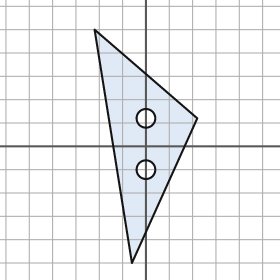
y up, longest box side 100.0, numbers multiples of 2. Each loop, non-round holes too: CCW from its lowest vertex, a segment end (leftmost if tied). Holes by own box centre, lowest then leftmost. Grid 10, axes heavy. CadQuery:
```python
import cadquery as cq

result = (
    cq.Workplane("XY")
    .moveTo(-6.0, -50.0)
    .lineTo(22.0, 12.0)
    .lineTo(-22.0, 50.0)
    .close()
    .moveTo(0.0, -10.0)
    .circle(4.0)
    .moveTo(0.0, 12.0)
    .circle(4.0)
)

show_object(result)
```